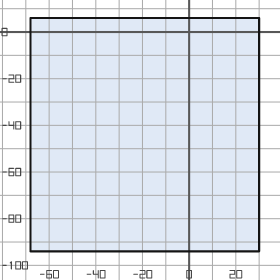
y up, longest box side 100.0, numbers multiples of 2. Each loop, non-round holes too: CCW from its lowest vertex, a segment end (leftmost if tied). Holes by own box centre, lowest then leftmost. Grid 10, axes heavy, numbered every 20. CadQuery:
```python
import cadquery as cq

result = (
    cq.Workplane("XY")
    .moveTo(-68.0, -94.0)
    .lineTo(30.0, -94.0)
    .lineTo(30.0, 6.0)
    .lineTo(-68.0, 6.0)
    .close()
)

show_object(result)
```